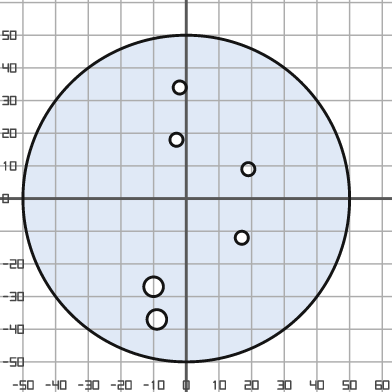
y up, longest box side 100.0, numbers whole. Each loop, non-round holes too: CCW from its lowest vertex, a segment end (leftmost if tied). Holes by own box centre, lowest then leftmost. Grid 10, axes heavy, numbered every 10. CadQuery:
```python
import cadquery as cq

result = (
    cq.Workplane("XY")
    .moveTo(0.0, 0.0)
    .circle(50.0)
    .moveTo(-9.0, -37.0)
    .circle(3.0)
    .moveTo(-10.0, -27.0)
    .circle(3.0)
    .moveTo(17.0, -12.0)
    .circle(2.0)
    .moveTo(19.0, 9.0)
    .circle(2.0)
    .moveTo(-3.0, 18.0)
    .circle(2.0)
    .moveTo(-2.0, 34.0)
    .circle(2.0)
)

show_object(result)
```